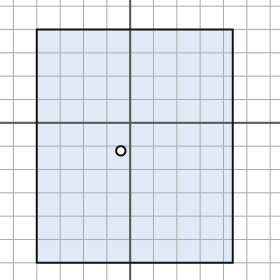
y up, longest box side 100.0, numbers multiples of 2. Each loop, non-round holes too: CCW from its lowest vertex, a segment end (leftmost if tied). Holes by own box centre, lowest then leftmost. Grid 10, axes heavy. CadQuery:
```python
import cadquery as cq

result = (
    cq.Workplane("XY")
    .moveTo(-40.0, -60.0)
    .lineTo(44.0, -60.0)
    .lineTo(44.0, 40.0)
    .lineTo(-40.0, 40.0)
    .close()
    .moveTo(-4.0, -12.0)
    .circle(2.0)
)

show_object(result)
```